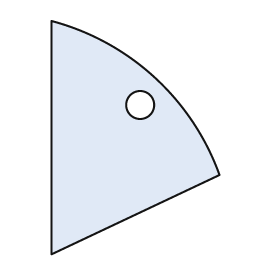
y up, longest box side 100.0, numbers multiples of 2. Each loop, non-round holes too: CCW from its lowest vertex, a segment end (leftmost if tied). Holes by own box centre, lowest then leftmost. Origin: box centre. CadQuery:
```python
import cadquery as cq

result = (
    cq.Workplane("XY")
    .moveTo(-36.0, -50.0)
    .lineTo(36.0, -16.0)
    .threePointArc((8.0, 26.0), (-36.0, 50.0))
    .close()
    .moveTo(2.0, 14.0)
    .circle(6.0)
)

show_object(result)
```